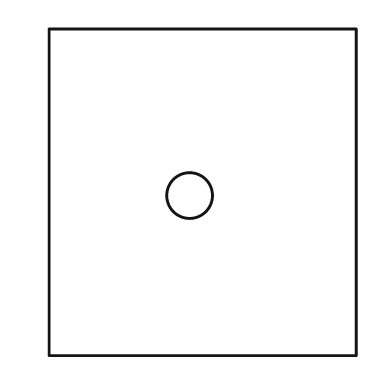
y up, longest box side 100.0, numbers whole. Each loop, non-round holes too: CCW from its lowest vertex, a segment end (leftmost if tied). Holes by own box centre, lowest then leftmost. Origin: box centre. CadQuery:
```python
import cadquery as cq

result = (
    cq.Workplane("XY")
    .moveTo(-47.0, -50.0)
    .lineTo(47.0, -50.0)
    .lineTo(47.0, 50.0)
    .lineTo(-47.0, 50.0)
    .close()
    .moveTo(-4.0, -1.0)
    .circle(7.0)
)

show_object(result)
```